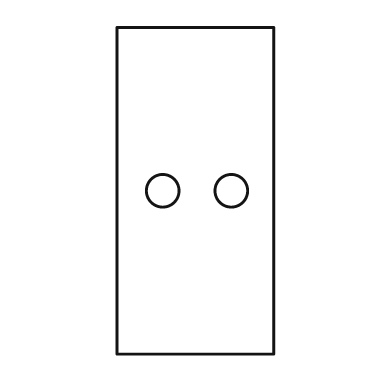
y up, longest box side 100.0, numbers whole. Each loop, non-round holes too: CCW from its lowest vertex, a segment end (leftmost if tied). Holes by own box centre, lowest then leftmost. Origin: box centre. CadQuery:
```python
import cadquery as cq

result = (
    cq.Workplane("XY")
    .moveTo(-24.0, -50.0)
    .lineTo(24.0, -50.0)
    .lineTo(24.0, 50.0)
    .lineTo(-24.0, 50.0)
    .close()
    .moveTo(-10.0, 0.0)
    .circle(5.0)
    .moveTo(11.0, 0.0)
    .circle(5.0)
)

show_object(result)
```